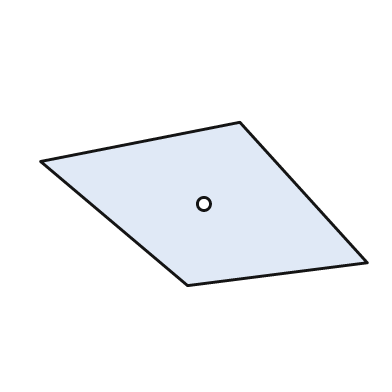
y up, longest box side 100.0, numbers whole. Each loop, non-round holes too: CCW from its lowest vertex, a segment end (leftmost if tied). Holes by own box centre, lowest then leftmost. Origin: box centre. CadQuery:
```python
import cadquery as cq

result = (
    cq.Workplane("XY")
    .moveTo(-5.0, -25.0)
    .lineTo(50.0, -18.0)
    .lineTo(11.0, 25.0)
    .lineTo(-50.0, 13.0)
    .close()
    .moveTo(0.0, 0.0)
    .circle(2.0)
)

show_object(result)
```